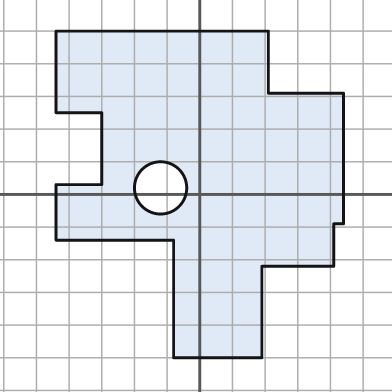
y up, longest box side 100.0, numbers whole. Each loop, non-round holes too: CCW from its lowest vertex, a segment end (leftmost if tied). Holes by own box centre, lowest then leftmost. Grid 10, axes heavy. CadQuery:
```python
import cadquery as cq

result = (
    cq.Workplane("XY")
    .moveTo(-8.0, -50.0)
    .lineTo(19.0, -50.0)
    .lineTo(19.0, -22.0)
    .lineTo(41.0, -22.0)
    .lineTo(41.0, -9.0)
    .lineTo(44.0, -9.0)
    .lineTo(44.0, 31.0)
    .lineTo(21.0, 31.0)
    .lineTo(21.0, 50.0)
    .lineTo(-44.0, 50.0)
    .lineTo(-44.0, 25.0)
    .lineTo(-30.0, 25.0)
    .lineTo(-30.0, 3.0)
    .lineTo(-44.0, 3.0)
    .lineTo(-44.0, -14.0)
    .lineTo(-8.0, -14.0)
    .close()
    .moveTo(-12.0, 2.0)
    .circle(8.0)
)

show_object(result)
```